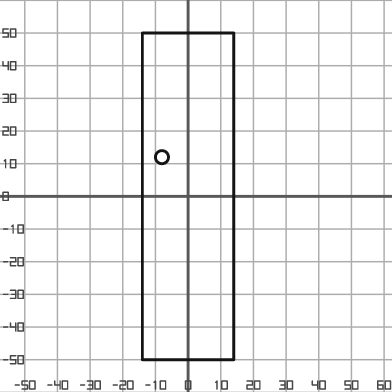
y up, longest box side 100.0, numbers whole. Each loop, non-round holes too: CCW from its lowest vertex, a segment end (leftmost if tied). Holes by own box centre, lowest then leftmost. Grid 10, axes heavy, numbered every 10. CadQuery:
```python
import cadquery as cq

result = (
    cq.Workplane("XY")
    .moveTo(-14.0, -50.0)
    .lineTo(14.0, -50.0)
    .lineTo(14.0, 50.0)
    .lineTo(-14.0, 50.0)
    .close()
    .moveTo(-8.0, 12.0)
    .circle(2.0)
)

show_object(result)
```